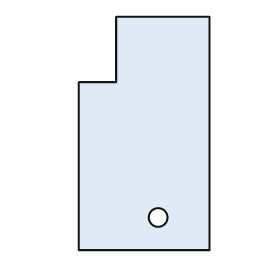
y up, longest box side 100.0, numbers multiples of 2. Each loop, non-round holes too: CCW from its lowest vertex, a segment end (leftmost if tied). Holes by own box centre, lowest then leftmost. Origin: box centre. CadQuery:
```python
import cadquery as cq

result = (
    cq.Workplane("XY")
    .moveTo(-28.0, -50.0)
    .lineTo(28.0, -50.0)
    .lineTo(28.0, 50.0)
    .lineTo(-12.0, 50.0)
    .lineTo(-12.0, 22.0)
    .lineTo(-28.0, 22.0)
    .close()
    .moveTo(6.0, -36.0)
    .circle(4.0)
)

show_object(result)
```